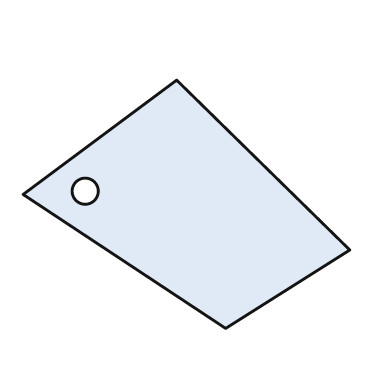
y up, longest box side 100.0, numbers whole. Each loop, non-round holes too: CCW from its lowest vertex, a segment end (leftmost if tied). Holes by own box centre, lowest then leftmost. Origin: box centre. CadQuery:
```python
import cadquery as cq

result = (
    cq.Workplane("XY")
    .moveTo(12.0, -38.0)
    .lineTo(50.0, -14.0)
    .lineTo(-3.0, 38.0)
    .lineTo(-50.0, 3.0)
    .close()
    .moveTo(-31.0, 4.0)
    .circle(4.0)
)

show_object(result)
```